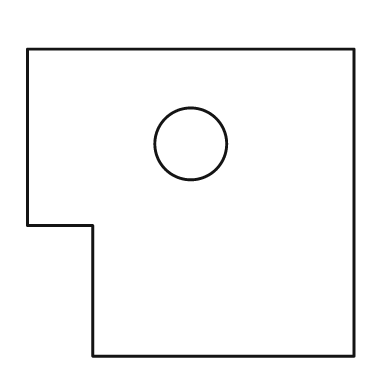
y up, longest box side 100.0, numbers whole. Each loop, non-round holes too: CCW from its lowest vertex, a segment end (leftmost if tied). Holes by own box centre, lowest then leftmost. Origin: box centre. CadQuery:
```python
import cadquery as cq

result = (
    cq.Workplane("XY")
    .moveTo(-30.0, -47.0)
    .lineTo(50.0, -47.0)
    .lineTo(50.0, 47.0)
    .lineTo(-50.0, 47.0)
    .lineTo(-50.0, -7.0)
    .lineTo(-30.0, -7.0)
    .close()
    .moveTo(0.0, 18.0)
    .circle(11.0)
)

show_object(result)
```